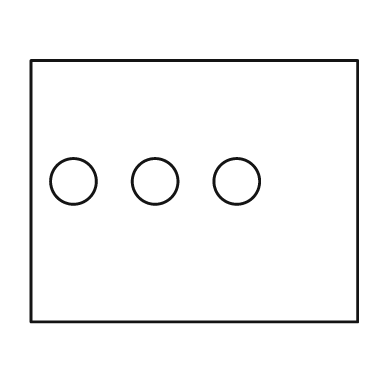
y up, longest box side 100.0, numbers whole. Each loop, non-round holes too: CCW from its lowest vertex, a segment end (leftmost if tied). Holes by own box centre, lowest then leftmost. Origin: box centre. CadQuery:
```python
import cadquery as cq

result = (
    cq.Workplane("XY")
    .moveTo(-50.0, -40.0)
    .lineTo(50.0, -40.0)
    .lineTo(50.0, 40.0)
    .lineTo(-50.0, 40.0)
    .close()
    .moveTo(-37.0, 3.0)
    .circle(7.0)
    .moveTo(-12.0, 3.0)
    .circle(7.0)
    .moveTo(13.0, 3.0)
    .circle(7.0)
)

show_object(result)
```